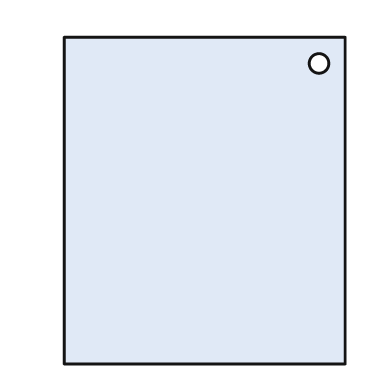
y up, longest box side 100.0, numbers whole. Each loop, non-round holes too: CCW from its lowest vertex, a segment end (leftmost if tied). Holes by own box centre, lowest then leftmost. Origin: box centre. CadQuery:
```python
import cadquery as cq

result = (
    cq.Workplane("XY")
    .moveTo(-43.0, -50.0)
    .lineTo(43.0, -50.0)
    .lineTo(43.0, 50.0)
    .lineTo(-43.0, 50.0)
    .close()
    .moveTo(35.0, 42.0)
    .circle(3.0)
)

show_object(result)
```